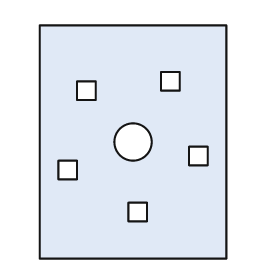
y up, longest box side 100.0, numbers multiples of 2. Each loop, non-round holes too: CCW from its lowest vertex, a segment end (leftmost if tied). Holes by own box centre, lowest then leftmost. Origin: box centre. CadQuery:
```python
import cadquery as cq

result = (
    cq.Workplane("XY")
    .moveTo(-40.0, -50.0)
    .lineTo(40.0, -50.0)
    .lineTo(40.0, 50.0)
    .lineTo(-40.0, 50.0)
    .close()
    .moveTo(-2.0, -34.0)
    .lineTo(6.0, -34.0)
    .lineTo(6.0, -26.0)
    .lineTo(-2.0, -26.0)
    .close()
    .moveTo(-32.0, -16.0)
    .lineTo(-24.0, -16.0)
    .lineTo(-24.0, -8.0)
    .lineTo(-32.0, -8.0)
    .close()
    .moveTo(24.0, -10.0)
    .lineTo(32.0, -10.0)
    .lineTo(32.0, -2.0)
    .lineTo(24.0, -2.0)
    .close()
    .moveTo(0.0, 0.0)
    .circle(8.0)
    .moveTo(-24.0, 18.0)
    .lineTo(-16.0, 18.0)
    .lineTo(-16.0, 26.0)
    .lineTo(-24.0, 26.0)
    .close()
    .moveTo(12.0, 22.0)
    .lineTo(20.0, 22.0)
    .lineTo(20.0, 30.0)
    .lineTo(12.0, 30.0)
    .close()
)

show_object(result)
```